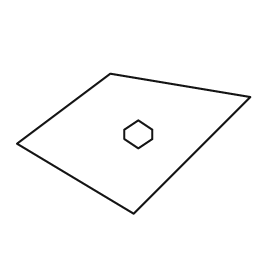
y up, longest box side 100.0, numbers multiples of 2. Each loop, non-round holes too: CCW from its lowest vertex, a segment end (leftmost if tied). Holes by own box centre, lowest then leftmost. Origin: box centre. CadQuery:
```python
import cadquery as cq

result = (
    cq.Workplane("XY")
    .moveTo(0.0, -30.0)
    .lineTo(50.0, 20.0)
    .lineTo(-10.0, 30.0)
    .lineTo(-50.0, 0.0)
    .close()
    .moveTo(2.0, -2.0)
    .lineTo(8.0, 2.0)
    .lineTo(8.0, 6.0)
    .lineTo(2.0, 10.0)
    .lineTo(-4.0, 6.0)
    .lineTo(-4.0, 2.0)
    .close()
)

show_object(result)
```